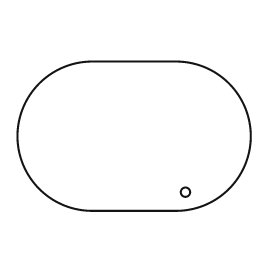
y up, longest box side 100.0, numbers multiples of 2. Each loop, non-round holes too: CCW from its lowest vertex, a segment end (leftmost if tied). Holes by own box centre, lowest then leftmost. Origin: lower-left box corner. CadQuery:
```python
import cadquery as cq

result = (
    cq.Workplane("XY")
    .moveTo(32.0, 0.0)
    .lineTo(68.0, 0.0)
    .threePointArc((100.0, 32.0), (68.0, 64.0))
    .lineTo(32.0, 64.0)
    .threePointArc((0.0, 32.0), (32.0, 0.0))
    .close()
    .moveTo(72.0, 8.0)
    .circle(2.0)
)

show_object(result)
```